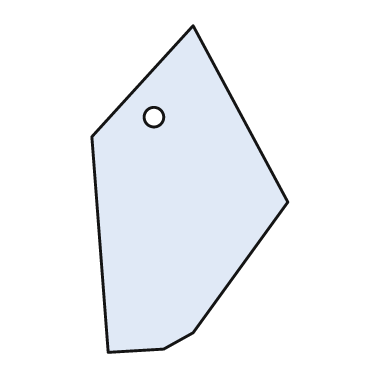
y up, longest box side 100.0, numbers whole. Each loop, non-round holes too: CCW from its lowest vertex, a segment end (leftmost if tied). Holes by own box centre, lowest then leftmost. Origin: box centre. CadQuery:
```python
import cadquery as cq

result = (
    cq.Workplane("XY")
    .moveTo(-25.0, -50.0)
    .lineTo(-8.0, -49.0)
    .lineTo(1.0, -44.0)
    .lineTo(30.0, -4.0)
    .lineTo(1.0, 50.0)
    .lineTo(-30.0, 16.0)
    .close()
    .moveTo(-11.0, 22.0)
    .circle(3.0)
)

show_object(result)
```